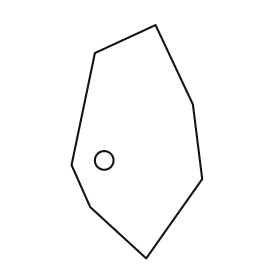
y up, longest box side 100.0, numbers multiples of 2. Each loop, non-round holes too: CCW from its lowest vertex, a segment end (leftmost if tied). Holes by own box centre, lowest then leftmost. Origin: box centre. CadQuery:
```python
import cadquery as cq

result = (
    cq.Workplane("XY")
    .moveTo(4.0, -50.0)
    .lineTo(28.0, -16.0)
    .lineTo(24.0, 16.0)
    .lineTo(8.0, 50.0)
    .lineTo(-18.0, 38.0)
    .lineTo(-28.0, -10.0)
    .lineTo(-20.0, -28.0)
    .close()
    .moveTo(-14.0, -8.0)
    .circle(4.0)
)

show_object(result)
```